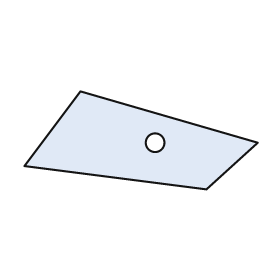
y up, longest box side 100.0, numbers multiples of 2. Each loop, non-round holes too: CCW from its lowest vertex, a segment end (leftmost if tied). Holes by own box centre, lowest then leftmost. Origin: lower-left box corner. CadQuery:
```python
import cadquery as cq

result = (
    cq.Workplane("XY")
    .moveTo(78.0, 0.0)
    .lineTo(100.0, 20.0)
    .lineTo(24.0, 42.0)
    .lineTo(0.0, 10.0)
    .close()
    .moveTo(56.0, 20.0)
    .circle(4.0)
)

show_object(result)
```